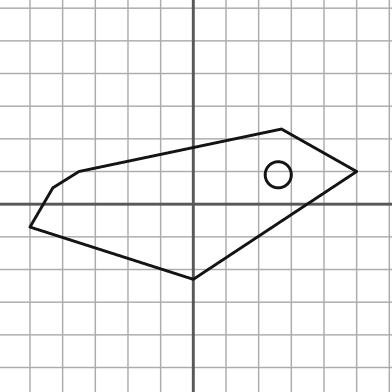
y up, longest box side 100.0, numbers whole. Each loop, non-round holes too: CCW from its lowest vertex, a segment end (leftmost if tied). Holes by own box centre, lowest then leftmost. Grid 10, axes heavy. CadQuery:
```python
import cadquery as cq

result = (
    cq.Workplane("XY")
    .moveTo(0.0, -23.0)
    .lineTo(50.0, 10.0)
    .lineTo(27.0, 23.0)
    .lineTo(-35.0, 10.0)
    .lineTo(-43.0, 5.0)
    .lineTo(-50.0, -7.0)
    .close()
    .moveTo(26.0, 9.0)
    .circle(4.0)
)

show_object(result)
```